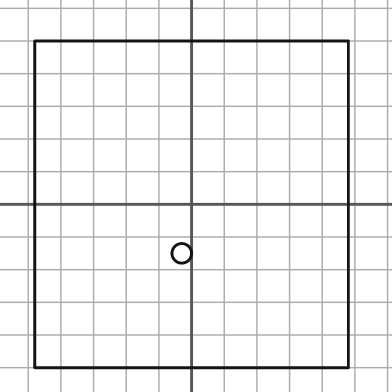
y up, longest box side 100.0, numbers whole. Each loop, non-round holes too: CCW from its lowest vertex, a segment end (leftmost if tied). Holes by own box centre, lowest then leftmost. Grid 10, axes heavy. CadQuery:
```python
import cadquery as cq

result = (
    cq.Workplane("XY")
    .moveTo(-48.0, -50.0)
    .lineTo(48.0, -50.0)
    .lineTo(48.0, 50.0)
    .lineTo(-48.0, 50.0)
    .close()
    .moveTo(-3.0, -15.0)
    .circle(3.0)
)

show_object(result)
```